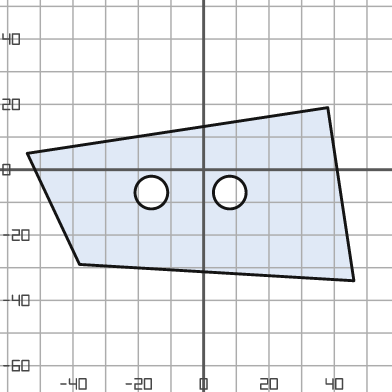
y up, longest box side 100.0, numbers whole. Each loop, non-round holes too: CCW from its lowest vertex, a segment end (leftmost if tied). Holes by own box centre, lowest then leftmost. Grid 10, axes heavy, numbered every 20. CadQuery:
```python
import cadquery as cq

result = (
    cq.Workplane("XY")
    .moveTo(46.0, -34.0)
    .lineTo(38.0, 19.0)
    .lineTo(-54.0, 5.0)
    .lineTo(-38.0, -29.0)
    .close()
    .moveTo(-16.0, -7.0)
    .circle(5.0)
    .moveTo(8.0, -7.0)
    .circle(5.0)
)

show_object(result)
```